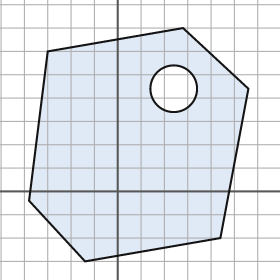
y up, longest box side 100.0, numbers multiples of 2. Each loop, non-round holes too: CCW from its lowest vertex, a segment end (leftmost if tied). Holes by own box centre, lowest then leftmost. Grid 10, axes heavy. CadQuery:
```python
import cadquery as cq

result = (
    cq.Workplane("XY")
    .moveTo(-14.0, -30.0)
    .lineTo(44.0, -20.0)
    .lineTo(56.0, 44.0)
    .lineTo(28.0, 70.0)
    .lineTo(-30.0, 60.0)
    .lineTo(-38.0, -4.0)
    .close()
    .moveTo(24.0, 44.0)
    .circle(10.0)
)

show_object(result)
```